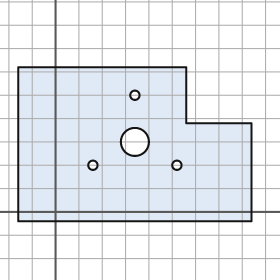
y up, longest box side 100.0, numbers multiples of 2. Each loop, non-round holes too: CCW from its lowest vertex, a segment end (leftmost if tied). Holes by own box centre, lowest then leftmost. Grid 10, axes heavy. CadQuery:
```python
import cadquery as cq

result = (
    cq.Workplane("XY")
    .moveTo(-16.0, -4.0)
    .lineTo(84.0, -4.0)
    .lineTo(84.0, 38.0)
    .lineTo(56.0, 38.0)
    .lineTo(56.0, 62.0)
    .lineTo(-16.0, 62.0)
    .close()
    .moveTo(16.0, 20.0)
    .circle(2.0)
    .moveTo(52.0, 20.0)
    .circle(2.0)
    .moveTo(34.0, 30.0)
    .circle(6.0)
    .moveTo(34.0, 50.0)
    .circle(2.0)
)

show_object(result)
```